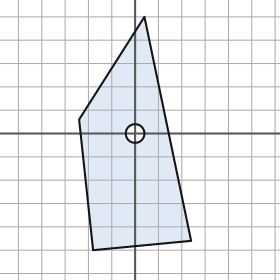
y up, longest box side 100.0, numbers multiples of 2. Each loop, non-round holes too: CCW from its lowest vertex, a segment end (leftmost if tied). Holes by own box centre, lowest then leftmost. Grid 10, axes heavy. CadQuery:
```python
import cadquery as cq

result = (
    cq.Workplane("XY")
    .moveTo(-18.0, -50.0)
    .lineTo(24.0, -46.0)
    .lineTo(4.0, 50.0)
    .lineTo(-24.0, 6.0)
    .close()
    .moveTo(0.0, 0.0)
    .circle(4.0)
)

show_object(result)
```